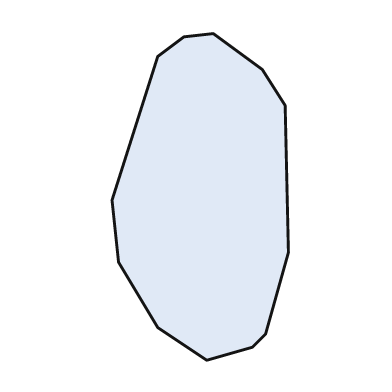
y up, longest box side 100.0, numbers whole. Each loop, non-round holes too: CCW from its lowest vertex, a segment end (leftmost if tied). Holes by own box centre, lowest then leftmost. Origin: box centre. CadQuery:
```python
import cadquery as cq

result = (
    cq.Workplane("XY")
    .moveTo(2.0, -50.0)
    .lineTo(16.0, -46.0)
    .lineTo(20.0, -42.0)
    .lineTo(27.0, -17.0)
    .lineTo(26.0, 28.0)
    .lineTo(19.0, 39.0)
    .lineTo(4.0, 50.0)
    .lineTo(-5.0, 49.0)
    .lineTo(-13.0, 43.0)
    .lineTo(-27.0, -1.0)
    .lineTo(-25.0, -20.0)
    .lineTo(-13.0, -40.0)
    .close()
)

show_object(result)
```